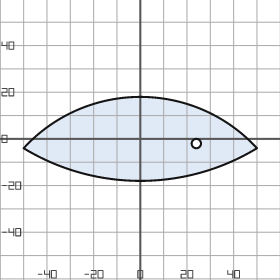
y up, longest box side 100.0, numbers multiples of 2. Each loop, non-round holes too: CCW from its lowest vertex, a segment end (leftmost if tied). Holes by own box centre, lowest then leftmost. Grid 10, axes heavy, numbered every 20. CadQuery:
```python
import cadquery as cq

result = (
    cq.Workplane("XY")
    .moveTo(-50.0, -4.0)
    .threePointArc((0.0, -18.0), (50.0, -4.0))
    .threePointArc((0.0, 18.0), (-50.0, -4.0))
    .close()
    .moveTo(24.0, -2.0)
    .circle(2.0)
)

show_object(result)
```